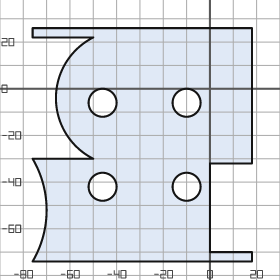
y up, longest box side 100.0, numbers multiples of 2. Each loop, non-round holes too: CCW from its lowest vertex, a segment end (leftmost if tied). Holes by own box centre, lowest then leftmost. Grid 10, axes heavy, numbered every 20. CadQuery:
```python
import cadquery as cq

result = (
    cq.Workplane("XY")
    .moveTo(-76.0, -74.0)
    .lineTo(18.0, -74.0)
    .lineTo(18.0, -70.0)
    .lineTo(0.0, -70.0)
    .lineTo(0.0, -32.0)
    .lineTo(18.0, -32.0)
    .lineTo(18.0, 26.0)
    .lineTo(-76.0, 26.0)
    .lineTo(-76.0, 22.0)
    .lineTo(-50.0, 22.0)
    .threePointArc((-66.0, -4.0), (-50.0, -30.0))
    .lineTo(-76.0, -30.0)
    .threePointArc((-70.0, -52.0), (-76.0, -74.0))
    .close()
    .moveTo(-46.0, -42.0)
    .circle(6.0)
    .moveTo(-10.0, -42.0)
    .circle(6.0)
    .moveTo(-46.0, -6.0)
    .circle(6.0)
    .moveTo(-10.0, -6.0)
    .circle(6.0)
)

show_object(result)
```